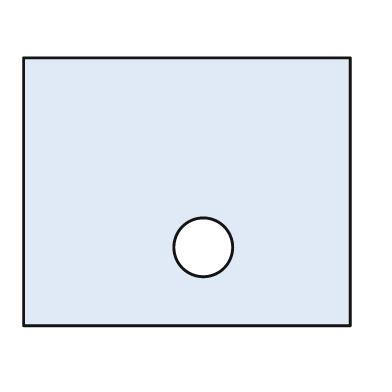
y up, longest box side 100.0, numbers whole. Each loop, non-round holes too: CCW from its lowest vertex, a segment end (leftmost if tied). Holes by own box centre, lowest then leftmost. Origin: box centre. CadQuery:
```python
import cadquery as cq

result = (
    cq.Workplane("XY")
    .moveTo(-50.0, -41.0)
    .lineTo(50.0, -41.0)
    .lineTo(50.0, 41.0)
    .lineTo(-50.0, 41.0)
    .close()
    .moveTo(5.0, -17.0)
    .circle(9.0)
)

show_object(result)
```